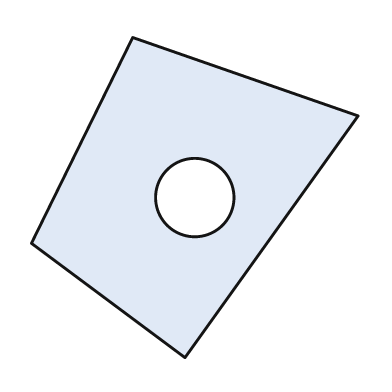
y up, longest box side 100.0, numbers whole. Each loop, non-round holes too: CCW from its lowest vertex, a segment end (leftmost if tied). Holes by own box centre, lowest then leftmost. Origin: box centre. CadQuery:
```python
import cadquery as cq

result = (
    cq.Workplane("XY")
    .moveTo(-3.0, -49.0)
    .lineTo(50.0, 25.0)
    .lineTo(-19.0, 49.0)
    .lineTo(-50.0, -14.0)
    .close()
    .moveTo(0.0, 0.0)
    .circle(12.0)
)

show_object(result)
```